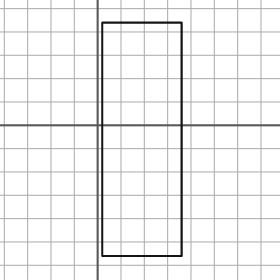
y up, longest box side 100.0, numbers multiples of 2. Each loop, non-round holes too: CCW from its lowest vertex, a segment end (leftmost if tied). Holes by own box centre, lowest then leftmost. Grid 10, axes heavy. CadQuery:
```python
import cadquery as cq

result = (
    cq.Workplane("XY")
    .moveTo(2.0, -56.0)
    .lineTo(36.0, -56.0)
    .lineTo(36.0, 44.0)
    .lineTo(2.0, 44.0)
    .close()
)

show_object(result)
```